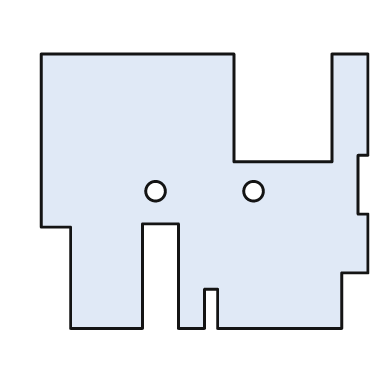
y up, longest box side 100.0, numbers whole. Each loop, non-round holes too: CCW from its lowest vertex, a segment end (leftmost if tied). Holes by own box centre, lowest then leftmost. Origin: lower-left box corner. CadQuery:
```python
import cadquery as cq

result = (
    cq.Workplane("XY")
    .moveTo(9.0, 0.0)
    .lineTo(31.0, 0.0)
    .lineTo(31.0, 32.0)
    .lineTo(42.0, 32.0)
    .lineTo(42.0, 0.0)
    .lineTo(50.0, 0.0)
    .lineTo(50.0, 12.0)
    .lineTo(54.0, 12.0)
    .lineTo(54.0, 0.0)
    .lineTo(92.0, 0.0)
    .lineTo(92.0, 17.0)
    .lineTo(100.0, 17.0)
    .lineTo(100.0, 35.0)
    .lineTo(97.0, 35.0)
    .lineTo(97.0, 53.0)
    .lineTo(100.0, 53.0)
    .lineTo(100.0, 84.0)
    .lineTo(89.0, 84.0)
    .lineTo(89.0, 51.0)
    .lineTo(59.0, 51.0)
    .lineTo(59.0, 84.0)
    .lineTo(0.0, 84.0)
    .lineTo(0.0, 31.0)
    .lineTo(9.0, 31.0)
    .close()
    .moveTo(35.0, 42.0)
    .circle(3.0)
    .moveTo(65.0, 42.0)
    .circle(3.0)
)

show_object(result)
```